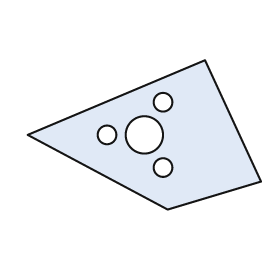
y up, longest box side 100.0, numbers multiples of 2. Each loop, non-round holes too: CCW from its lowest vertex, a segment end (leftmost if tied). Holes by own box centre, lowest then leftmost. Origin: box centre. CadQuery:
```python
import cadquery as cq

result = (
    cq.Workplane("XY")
    .moveTo(10.0, -32.0)
    .lineTo(50.0, -20.0)
    .lineTo(26.0, 32.0)
    .lineTo(-50.0, 0.0)
    .close()
    .moveTo(8.0, -14.0)
    .circle(4.0)
    .moveTo(-16.0, 0.0)
    .circle(4.0)
    .moveTo(0.0, 0.0)
    .circle(8.0)
    .moveTo(8.0, 14.0)
    .circle(4.0)
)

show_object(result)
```